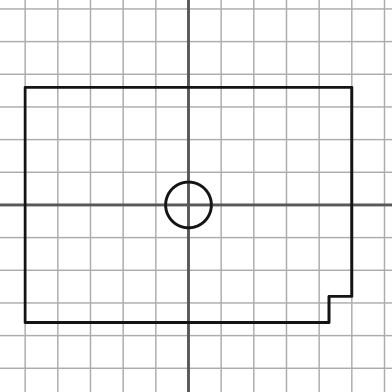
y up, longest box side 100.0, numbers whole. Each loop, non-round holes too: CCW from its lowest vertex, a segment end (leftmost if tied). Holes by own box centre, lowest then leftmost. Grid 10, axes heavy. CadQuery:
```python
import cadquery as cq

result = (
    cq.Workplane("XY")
    .moveTo(-50.0, -36.0)
    .lineTo(43.0, -36.0)
    .lineTo(43.0, -28.0)
    .lineTo(50.0, -28.0)
    .lineTo(50.0, 36.0)
    .lineTo(-50.0, 36.0)
    .close()
    .moveTo(0.0, 0.0)
    .circle(7.0)
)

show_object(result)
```